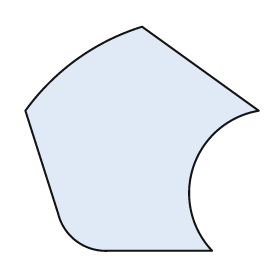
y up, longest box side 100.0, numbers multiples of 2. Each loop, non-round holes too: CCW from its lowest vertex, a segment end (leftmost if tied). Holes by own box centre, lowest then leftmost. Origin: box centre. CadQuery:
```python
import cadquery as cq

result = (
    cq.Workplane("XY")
    .moveTo(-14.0, -48.0)
    .lineTo(30.0, -48.0)
    .threePointArc((22.0, -12.0), (50.0, 12.0))
    .lineTo(0.0, 48.0)
    .threePointArc((-28.0, 34.0), (-50.0, 12.0))
    .lineTo(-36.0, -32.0)
    .threePointArc((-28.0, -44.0), (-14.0, -48.0))
    .close()
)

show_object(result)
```